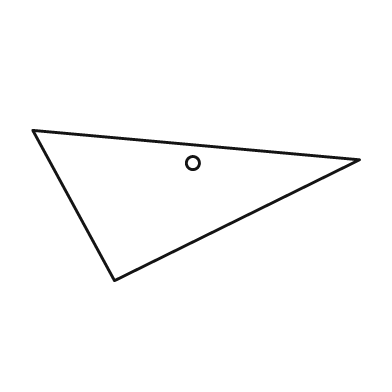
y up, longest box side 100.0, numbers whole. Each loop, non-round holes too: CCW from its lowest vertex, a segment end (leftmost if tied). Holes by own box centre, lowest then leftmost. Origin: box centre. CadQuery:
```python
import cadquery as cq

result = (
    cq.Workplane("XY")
    .moveTo(-25.0, -23.0)
    .lineTo(50.0, 14.0)
    .lineTo(-50.0, 23.0)
    .close()
    .moveTo(-1.0, 13.0)
    .circle(2.0)
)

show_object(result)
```